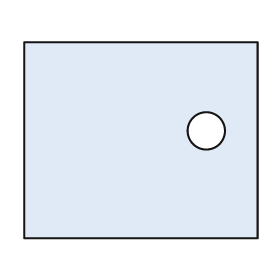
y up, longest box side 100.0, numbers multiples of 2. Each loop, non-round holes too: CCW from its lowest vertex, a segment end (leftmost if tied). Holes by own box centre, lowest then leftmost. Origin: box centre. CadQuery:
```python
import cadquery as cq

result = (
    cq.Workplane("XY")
    .moveTo(-50.0, -42.0)
    .lineTo(50.0, -42.0)
    .lineTo(50.0, 42.0)
    .lineTo(-50.0, 42.0)
    .close()
    .moveTo(28.0, 4.0)
    .circle(8.0)
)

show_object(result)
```